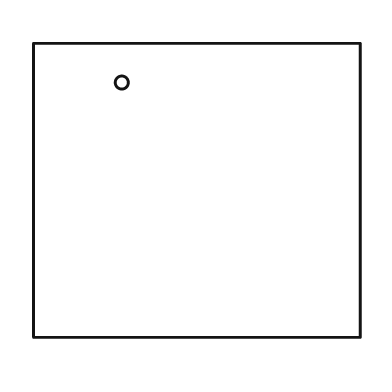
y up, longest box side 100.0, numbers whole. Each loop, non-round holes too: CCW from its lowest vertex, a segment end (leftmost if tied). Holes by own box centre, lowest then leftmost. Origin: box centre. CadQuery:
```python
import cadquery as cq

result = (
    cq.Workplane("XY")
    .moveTo(-50.0, -45.0)
    .lineTo(50.0, -45.0)
    .lineTo(50.0, 45.0)
    .lineTo(-50.0, 45.0)
    .close()
    .moveTo(-23.0, 33.0)
    .circle(2.0)
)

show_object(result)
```